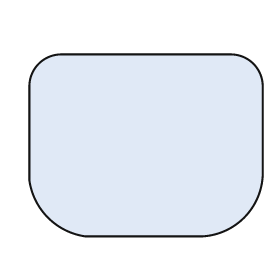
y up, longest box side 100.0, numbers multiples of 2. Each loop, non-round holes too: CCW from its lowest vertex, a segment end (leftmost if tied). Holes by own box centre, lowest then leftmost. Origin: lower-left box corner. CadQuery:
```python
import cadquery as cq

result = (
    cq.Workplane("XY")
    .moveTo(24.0, 0.0)
    .lineTo(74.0, 0.0)
    .threePointArc((92.0, 8.0), (100.0, 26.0))
    .lineTo(100.0, 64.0)
    .threePointArc((96.0, 74.0), (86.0, 78.0))
    .lineTo(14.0, 78.0)
    .threePointArc((4.0, 74.0), (0.0, 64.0))
    .lineTo(0.0, 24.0)
    .threePointArc((8.0, 8.0), (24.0, 0.0))
    .close()
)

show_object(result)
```